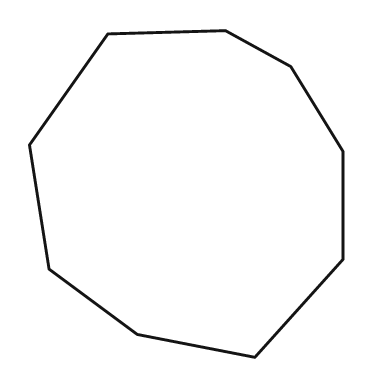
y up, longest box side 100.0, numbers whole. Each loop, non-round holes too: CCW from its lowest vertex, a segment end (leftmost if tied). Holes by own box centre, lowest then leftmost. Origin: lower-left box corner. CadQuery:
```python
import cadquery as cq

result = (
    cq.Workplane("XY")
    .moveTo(69.0, 0.0)
    .lineTo(96.0, 30.0)
    .lineTo(96.0, 63.0)
    .lineTo(80.0, 89.0)
    .lineTo(60.0, 100.0)
    .lineTo(24.0, 99.0)
    .lineTo(0.0, 65.0)
    .lineTo(6.0, 27.0)
    .lineTo(33.0, 7.0)
    .close()
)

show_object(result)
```